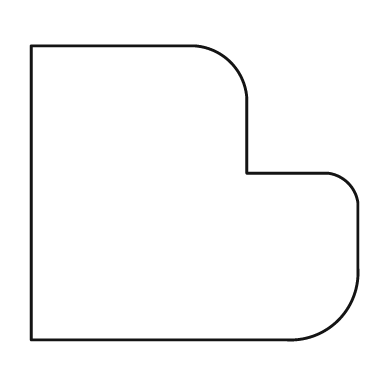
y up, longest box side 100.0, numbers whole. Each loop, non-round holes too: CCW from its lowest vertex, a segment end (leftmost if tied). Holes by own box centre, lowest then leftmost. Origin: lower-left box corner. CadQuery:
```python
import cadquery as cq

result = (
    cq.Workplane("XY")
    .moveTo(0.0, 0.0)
    .lineTo(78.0, 0.0)
    .threePointArc((94.0, 6.0), (100.0, 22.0))
    .lineTo(100.0, 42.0)
    .threePointArc((97.0, 48.0), (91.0, 51.0))
    .lineTo(66.0, 51.0)
    .lineTo(66.0, 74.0)
    .threePointArc((61.0, 85.0), (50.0, 90.0))
    .lineTo(0.0, 90.0)
    .close()
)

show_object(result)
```